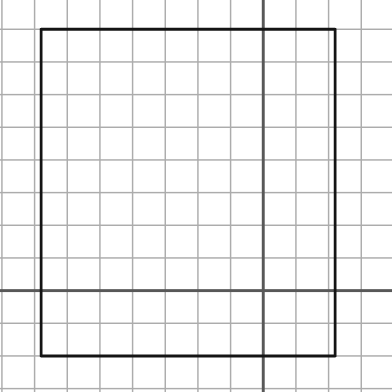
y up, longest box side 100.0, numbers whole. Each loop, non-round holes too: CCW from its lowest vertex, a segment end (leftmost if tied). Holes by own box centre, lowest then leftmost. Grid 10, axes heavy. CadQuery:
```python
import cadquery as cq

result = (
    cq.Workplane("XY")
    .moveTo(-68.0, -20.0)
    .lineTo(22.0, -20.0)
    .lineTo(22.0, 80.0)
    .lineTo(-68.0, 80.0)
    .close()
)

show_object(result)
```